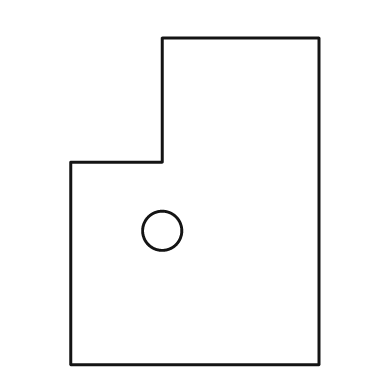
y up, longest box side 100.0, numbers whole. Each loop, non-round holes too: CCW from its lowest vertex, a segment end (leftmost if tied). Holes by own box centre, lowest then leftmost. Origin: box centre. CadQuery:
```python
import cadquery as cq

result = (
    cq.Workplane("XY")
    .moveTo(-38.0, -50.0)
    .lineTo(38.0, -50.0)
    .lineTo(38.0, 50.0)
    .lineTo(-10.0, 50.0)
    .lineTo(-10.0, 12.0)
    .lineTo(-38.0, 12.0)
    .close()
    .moveTo(-10.0, -9.0)
    .circle(6.0)
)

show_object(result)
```